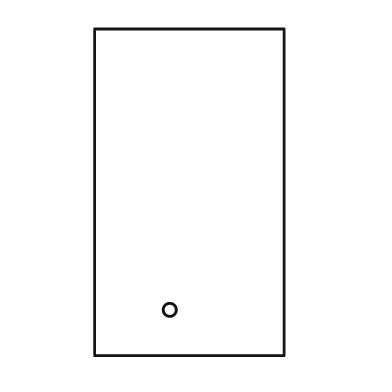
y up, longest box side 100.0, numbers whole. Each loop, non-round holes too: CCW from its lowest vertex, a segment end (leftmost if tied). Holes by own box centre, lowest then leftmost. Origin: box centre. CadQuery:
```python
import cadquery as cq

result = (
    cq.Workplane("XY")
    .moveTo(-29.0, -50.0)
    .lineTo(29.0, -50.0)
    .lineTo(29.0, 50.0)
    .lineTo(-29.0, 50.0)
    .close()
    .moveTo(-6.0, -36.0)
    .circle(2.0)
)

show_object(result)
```